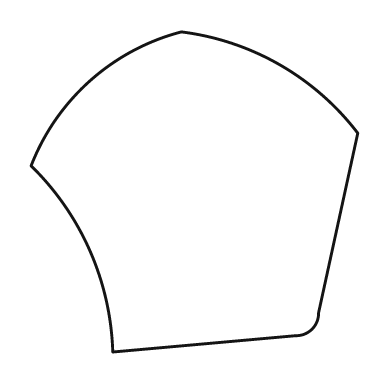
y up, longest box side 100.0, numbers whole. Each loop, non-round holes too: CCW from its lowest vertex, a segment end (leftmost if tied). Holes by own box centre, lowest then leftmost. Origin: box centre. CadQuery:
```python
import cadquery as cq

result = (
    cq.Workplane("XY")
    .moveTo(-25.0, -49.0)
    .lineTo(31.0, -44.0)
    .threePointArc((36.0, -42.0), (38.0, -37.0))
    .lineTo(50.0, 18.0)
    .threePointArc((26.0, 39.0), (-4.0, 49.0))
    .threePointArc((-32.0, 34.0), (-50.0, 8.0))
    .threePointArc((-32.0, -18.0), (-25.0, -49.0))
    .close()
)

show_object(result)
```